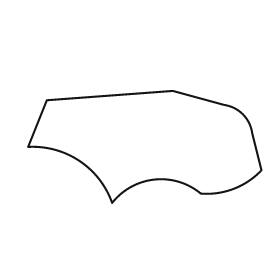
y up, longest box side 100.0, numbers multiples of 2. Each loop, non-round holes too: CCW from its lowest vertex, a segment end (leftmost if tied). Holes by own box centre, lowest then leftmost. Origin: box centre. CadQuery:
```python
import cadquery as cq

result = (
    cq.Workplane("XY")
    .moveTo(-14.0, -24.0)
    .threePointArc((4.0, -14.0), (24.0, -20.0))
    .threePointArc((38.0, -18.0), (50.0, -10.0))
    .lineTo(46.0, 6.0)
    .threePointArc((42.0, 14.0), (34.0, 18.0))
    .lineTo(12.0, 24.0)
    .lineTo(-42.0, 20.0)
    .lineTo(-50.0, 0.0)
    .threePointArc((-28.0, -6.0), (-14.0, -24.0))
    .close()
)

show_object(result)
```